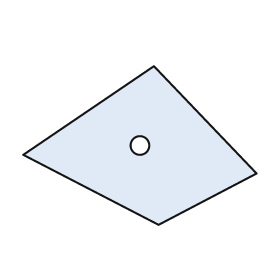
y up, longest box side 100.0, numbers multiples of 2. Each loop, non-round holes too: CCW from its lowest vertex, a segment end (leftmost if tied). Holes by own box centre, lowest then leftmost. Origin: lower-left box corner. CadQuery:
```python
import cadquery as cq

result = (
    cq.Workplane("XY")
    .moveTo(58.0, 0.0)
    .lineTo(100.0, 22.0)
    .lineTo(56.0, 68.0)
    .lineTo(0.0, 30.0)
    .close()
    .moveTo(50.0, 34.0)
    .circle(4.0)
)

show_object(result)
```